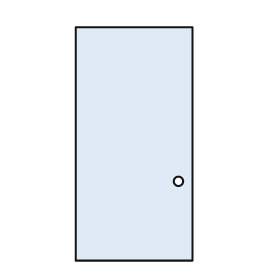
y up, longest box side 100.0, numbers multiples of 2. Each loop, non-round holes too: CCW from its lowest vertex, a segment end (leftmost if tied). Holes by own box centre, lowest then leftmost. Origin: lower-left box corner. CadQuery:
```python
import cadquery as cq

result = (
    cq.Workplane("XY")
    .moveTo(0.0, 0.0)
    .lineTo(50.0, 0.0)
    .lineTo(50.0, 100.0)
    .lineTo(0.0, 100.0)
    .close()
    .moveTo(44.0, 34.0)
    .circle(2.0)
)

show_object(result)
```